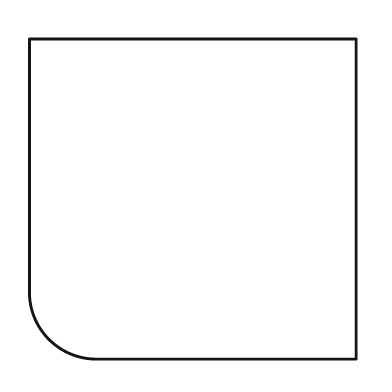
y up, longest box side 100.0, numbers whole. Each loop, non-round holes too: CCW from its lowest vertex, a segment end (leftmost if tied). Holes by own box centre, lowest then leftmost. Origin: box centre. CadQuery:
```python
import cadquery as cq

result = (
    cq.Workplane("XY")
    .moveTo(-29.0, -49.0)
    .lineTo(50.0, -49.0)
    .lineTo(50.0, 49.0)
    .lineTo(-50.0, 49.0)
    .lineTo(-50.0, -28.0)
    .threePointArc((-44.0, -43.0), (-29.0, -49.0))
    .close()
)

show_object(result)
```